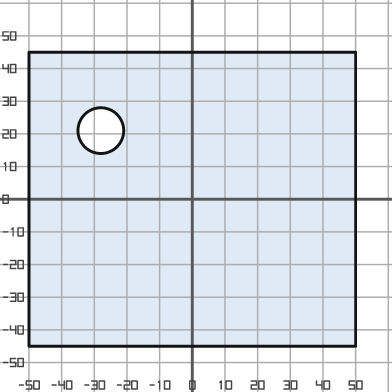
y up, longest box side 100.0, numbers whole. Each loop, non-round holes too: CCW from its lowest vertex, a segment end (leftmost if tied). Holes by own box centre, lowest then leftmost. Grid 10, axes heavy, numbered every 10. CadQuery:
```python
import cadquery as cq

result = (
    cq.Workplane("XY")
    .moveTo(-50.0, -45.0)
    .lineTo(50.0, -45.0)
    .lineTo(50.0, 45.0)
    .lineTo(-50.0, 45.0)
    .close()
    .moveTo(-28.0, 21.0)
    .circle(7.0)
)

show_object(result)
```